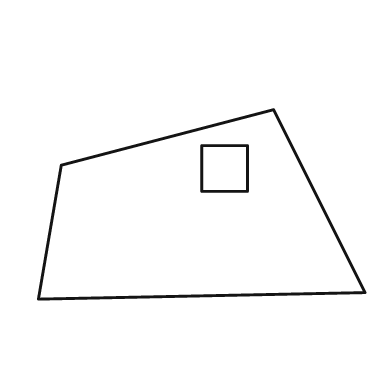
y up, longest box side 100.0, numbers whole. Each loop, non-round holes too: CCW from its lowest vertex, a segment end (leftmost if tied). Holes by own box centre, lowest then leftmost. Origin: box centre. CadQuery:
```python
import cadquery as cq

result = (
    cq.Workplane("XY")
    .moveTo(-50.0, -29.0)
    .lineTo(50.0, -27.0)
    .lineTo(22.0, 29.0)
    .lineTo(-43.0, 12.0)
    .close()
    .moveTo(0.0, 4.0)
    .lineTo(14.0, 4.0)
    .lineTo(14.0, 18.0)
    .lineTo(0.0, 18.0)
    .close()
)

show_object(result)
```